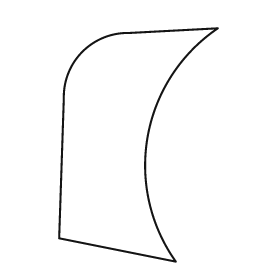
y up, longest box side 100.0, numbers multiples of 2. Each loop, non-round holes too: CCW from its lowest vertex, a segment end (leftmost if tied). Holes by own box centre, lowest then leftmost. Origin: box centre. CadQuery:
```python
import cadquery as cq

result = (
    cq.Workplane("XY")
    .moveTo(16.0, -50.0)
    .threePointArc((4.0, 4.0), (34.0, 50.0))
    .lineTo(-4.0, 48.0)
    .threePointArc((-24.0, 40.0), (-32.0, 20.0))
    .lineTo(-34.0, -40.0)
    .close()
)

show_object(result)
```